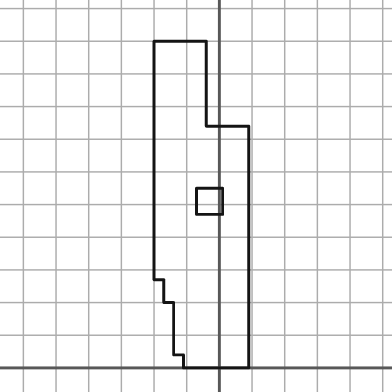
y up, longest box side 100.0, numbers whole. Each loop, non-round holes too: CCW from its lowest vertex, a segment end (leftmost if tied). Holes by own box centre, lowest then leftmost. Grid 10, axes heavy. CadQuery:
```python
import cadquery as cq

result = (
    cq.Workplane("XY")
    .moveTo(-11.0, 0.0)
    .lineTo(9.0, 0.0)
    .lineTo(9.0, 74.0)
    .lineTo(-4.0, 74.0)
    .lineTo(-4.0, 100.0)
    .lineTo(-20.0, 100.0)
    .lineTo(-20.0, 27.0)
    .lineTo(-17.0, 27.0)
    .lineTo(-17.0, 20.0)
    .lineTo(-14.0, 20.0)
    .lineTo(-14.0, 4.0)
    .lineTo(-11.0, 4.0)
    .close()
    .moveTo(-7.0, 47.0)
    .lineTo(1.0, 47.0)
    .lineTo(1.0, 55.0)
    .lineTo(-7.0, 55.0)
    .close()
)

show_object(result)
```